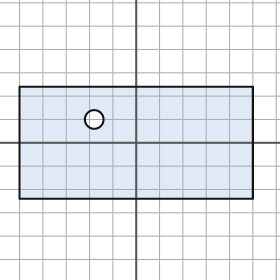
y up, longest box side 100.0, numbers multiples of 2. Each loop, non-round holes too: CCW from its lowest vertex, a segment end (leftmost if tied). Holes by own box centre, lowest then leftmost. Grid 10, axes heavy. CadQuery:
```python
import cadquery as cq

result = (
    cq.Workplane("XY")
    .moveTo(-50.0, -24.0)
    .lineTo(50.0, -24.0)
    .lineTo(50.0, 24.0)
    .lineTo(-50.0, 24.0)
    .close()
    .moveTo(-18.0, 10.0)
    .circle(4.0)
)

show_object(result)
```